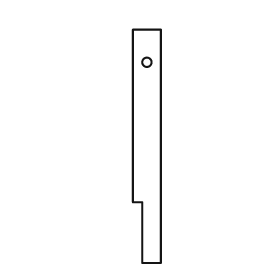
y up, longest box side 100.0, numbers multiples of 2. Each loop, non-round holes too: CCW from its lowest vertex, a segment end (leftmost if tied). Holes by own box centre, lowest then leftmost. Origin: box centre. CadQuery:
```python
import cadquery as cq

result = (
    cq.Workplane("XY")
    .moveTo(-2.0, -50.0)
    .lineTo(6.0, -50.0)
    .lineTo(6.0, 50.0)
    .lineTo(-6.0, 50.0)
    .lineTo(-6.0, -24.0)
    .lineTo(-2.0, -24.0)
    .close()
    .moveTo(0.0, 36.0)
    .circle(2.0)
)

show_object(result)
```